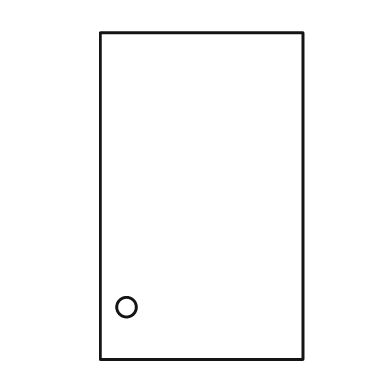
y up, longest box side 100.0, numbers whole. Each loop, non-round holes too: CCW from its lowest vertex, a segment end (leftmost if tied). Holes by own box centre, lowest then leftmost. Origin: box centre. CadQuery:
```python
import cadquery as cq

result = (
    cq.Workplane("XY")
    .moveTo(-31.0, -50.0)
    .lineTo(31.0, -50.0)
    .lineTo(31.0, 50.0)
    .lineTo(-31.0, 50.0)
    .close()
    .moveTo(-23.0, -34.0)
    .circle(3.0)
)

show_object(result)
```